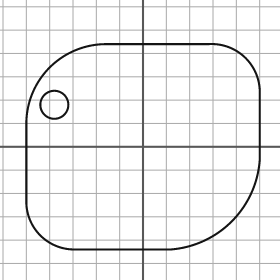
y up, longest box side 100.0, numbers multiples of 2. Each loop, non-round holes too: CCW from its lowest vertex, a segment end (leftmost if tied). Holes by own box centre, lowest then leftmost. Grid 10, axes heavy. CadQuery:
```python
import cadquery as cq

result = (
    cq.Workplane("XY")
    .moveTo(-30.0, -44.0)
    .lineTo(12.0, -44.0)
    .threePointArc((38.0, -32.0), (50.0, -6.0))
    .lineTo(50.0, 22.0)
    .threePointArc((44.0, 38.0), (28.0, 44.0))
    .lineTo(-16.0, 44.0)
    .threePointArc((-40.0, 34.0), (-50.0, 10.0))
    .lineTo(-50.0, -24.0)
    .threePointArc((-44.0, -38.0), (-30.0, -44.0))
    .close()
    .moveTo(-38.0, 18.0)
    .circle(6.0)
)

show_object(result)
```